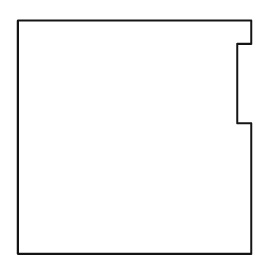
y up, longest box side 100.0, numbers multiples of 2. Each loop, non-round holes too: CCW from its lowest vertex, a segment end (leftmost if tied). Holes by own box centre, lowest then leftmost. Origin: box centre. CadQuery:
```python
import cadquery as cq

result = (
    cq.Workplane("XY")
    .moveTo(-50.0, -50.0)
    .lineTo(50.0, -50.0)
    .lineTo(50.0, 6.0)
    .lineTo(44.0, 6.0)
    .lineTo(44.0, 40.0)
    .lineTo(50.0, 40.0)
    .lineTo(50.0, 50.0)
    .lineTo(-50.0, 50.0)
    .close()
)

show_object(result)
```